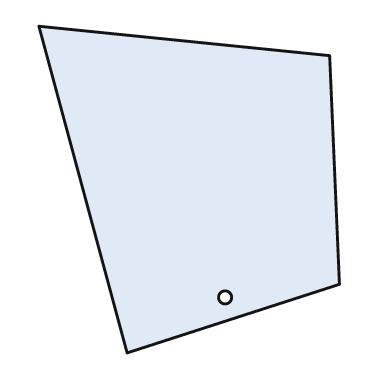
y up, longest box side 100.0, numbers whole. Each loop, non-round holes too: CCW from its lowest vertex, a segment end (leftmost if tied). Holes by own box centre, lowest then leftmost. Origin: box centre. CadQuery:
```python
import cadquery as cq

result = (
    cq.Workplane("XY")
    .moveTo(-19.0, -50.0)
    .lineTo(46.0, -29.0)
    .lineTo(43.0, 41.0)
    .lineTo(-46.0, 50.0)
    .close()
    .moveTo(11.0, -33.0)
    .circle(2.0)
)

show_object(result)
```